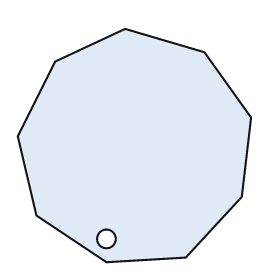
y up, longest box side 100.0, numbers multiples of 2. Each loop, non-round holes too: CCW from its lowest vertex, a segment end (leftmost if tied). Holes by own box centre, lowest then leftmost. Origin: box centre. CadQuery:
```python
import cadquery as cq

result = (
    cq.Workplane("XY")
    .moveTo(-12.0, -50.0)
    .lineTo(22.0, -48.0)
    .lineTo(46.0, -22.0)
    .lineTo(50.0, 12.0)
    .lineTo(30.0, 40.0)
    .lineTo(-4.0, 50.0)
    .lineTo(-34.0, 36.0)
    .lineTo(-50.0, 4.0)
    .lineTo(-42.0, -30.0)
    .close()
    .moveTo(-12.0, -40.0)
    .circle(4.0)
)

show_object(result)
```